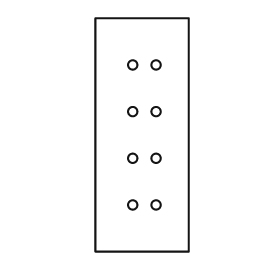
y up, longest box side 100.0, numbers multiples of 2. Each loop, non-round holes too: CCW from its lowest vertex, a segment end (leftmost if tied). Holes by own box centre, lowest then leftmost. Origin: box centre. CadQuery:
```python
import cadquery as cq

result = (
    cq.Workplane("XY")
    .moveTo(-20.0, -50.0)
    .lineTo(20.0, -50.0)
    .lineTo(20.0, 50.0)
    .lineTo(-20.0, 50.0)
    .close()
    .moveTo(-4.0, -30.0)
    .circle(2.0)
    .moveTo(6.0, -30.0)
    .circle(2.0)
    .moveTo(-4.0, -10.0)
    .circle(2.0)
    .moveTo(6.0, -10.0)
    .circle(2.0)
    .moveTo(-4.0, 10.0)
    .circle(2.0)
    .moveTo(6.0, 10.0)
    .circle(2.0)
    .moveTo(-4.0, 30.0)
    .circle(2.0)
    .moveTo(6.0, 30.0)
    .circle(2.0)
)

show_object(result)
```